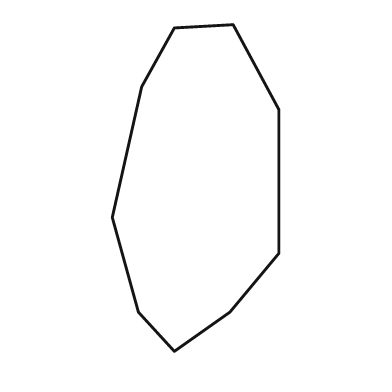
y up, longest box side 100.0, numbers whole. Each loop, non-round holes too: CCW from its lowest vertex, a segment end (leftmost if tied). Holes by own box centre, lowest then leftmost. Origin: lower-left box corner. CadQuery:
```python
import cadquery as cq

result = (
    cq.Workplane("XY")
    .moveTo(19.0, 0.0)
    .lineTo(36.0, 12.0)
    .lineTo(51.0, 30.0)
    .lineTo(51.0, 74.0)
    .lineTo(37.0, 100.0)
    .lineTo(19.0, 99.0)
    .lineTo(9.0, 81.0)
    .lineTo(0.0, 41.0)
    .lineTo(8.0, 12.0)
    .close()
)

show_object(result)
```